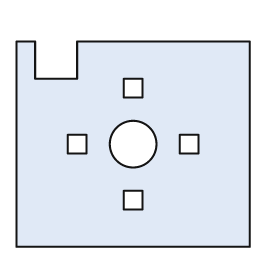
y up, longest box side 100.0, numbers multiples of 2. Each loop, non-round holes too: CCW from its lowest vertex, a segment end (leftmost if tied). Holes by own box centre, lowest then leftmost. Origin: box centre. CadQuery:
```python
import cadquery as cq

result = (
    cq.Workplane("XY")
    .moveTo(-50.0, -44.0)
    .lineTo(50.0, -44.0)
    .lineTo(50.0, 44.0)
    .lineTo(-24.0, 44.0)
    .lineTo(-24.0, 28.0)
    .lineTo(-42.0, 28.0)
    .lineTo(-42.0, 44.0)
    .lineTo(-50.0, 44.0)
    .close()
    .moveTo(-4.0, -28.0)
    .lineTo(4.0, -28.0)
    .lineTo(4.0, -20.0)
    .lineTo(-4.0, -20.0)
    .close()
    .moveTo(-28.0, -4.0)
    .lineTo(-20.0, -4.0)
    .lineTo(-20.0, 4.0)
    .lineTo(-28.0, 4.0)
    .close()
    .moveTo(0.0, 0.0)
    .circle(10.0)
    .moveTo(20.0, -4.0)
    .lineTo(28.0, -4.0)
    .lineTo(28.0, 4.0)
    .lineTo(20.0, 4.0)
    .close()
    .moveTo(-4.0, 20.0)
    .lineTo(4.0, 20.0)
    .lineTo(4.0, 28.0)
    .lineTo(-4.0, 28.0)
    .close()
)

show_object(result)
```